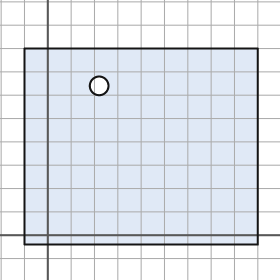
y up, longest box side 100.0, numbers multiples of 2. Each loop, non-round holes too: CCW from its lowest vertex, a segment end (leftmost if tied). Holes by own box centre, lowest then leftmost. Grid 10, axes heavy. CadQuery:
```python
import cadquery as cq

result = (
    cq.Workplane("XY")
    .moveTo(-10.0, -4.0)
    .lineTo(90.0, -4.0)
    .lineTo(90.0, 80.0)
    .lineTo(-10.0, 80.0)
    .close()
    .moveTo(22.0, 64.0)
    .circle(4.0)
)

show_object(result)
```